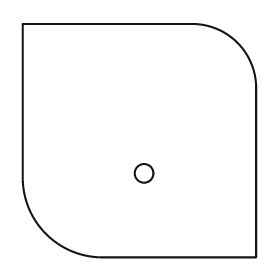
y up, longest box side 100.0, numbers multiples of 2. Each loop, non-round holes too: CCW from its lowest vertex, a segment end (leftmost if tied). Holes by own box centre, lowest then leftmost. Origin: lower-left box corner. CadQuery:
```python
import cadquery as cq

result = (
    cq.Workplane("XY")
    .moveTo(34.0, 0.0)
    .lineTo(100.0, 0.0)
    .lineTo(100.0, 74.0)
    .threePointArc((92.0, 92.0), (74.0, 100.0))
    .lineTo(0.0, 100.0)
    .lineTo(0.0, 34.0)
    .threePointArc((10.0, 10.0), (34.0, 0.0))
    .close()
    .moveTo(52.0, 36.0)
    .circle(4.0)
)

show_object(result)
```